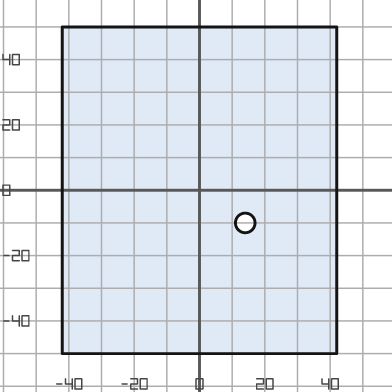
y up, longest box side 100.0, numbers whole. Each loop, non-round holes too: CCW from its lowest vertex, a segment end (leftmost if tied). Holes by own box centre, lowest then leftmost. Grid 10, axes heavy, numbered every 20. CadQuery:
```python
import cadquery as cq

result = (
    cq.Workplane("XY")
    .moveTo(-42.0, -50.0)
    .lineTo(42.0, -50.0)
    .lineTo(42.0, 50.0)
    .lineTo(-42.0, 50.0)
    .close()
    .moveTo(14.0, -10.0)
    .circle(3.0)
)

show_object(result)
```